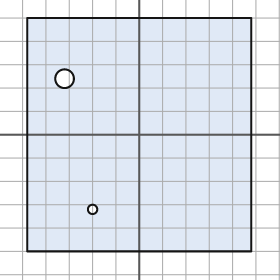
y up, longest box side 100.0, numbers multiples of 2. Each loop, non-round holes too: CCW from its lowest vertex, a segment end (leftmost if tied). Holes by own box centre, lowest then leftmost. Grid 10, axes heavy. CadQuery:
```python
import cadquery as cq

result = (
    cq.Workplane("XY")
    .moveTo(-48.0, -50.0)
    .lineTo(48.0, -50.0)
    .lineTo(48.0, 50.0)
    .lineTo(-48.0, 50.0)
    .close()
    .moveTo(-20.0, -32.0)
    .circle(2.0)
    .moveTo(-32.0, 24.0)
    .circle(4.0)
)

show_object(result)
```